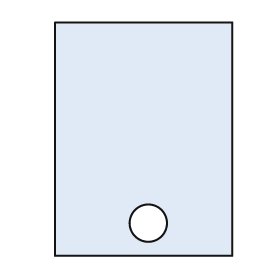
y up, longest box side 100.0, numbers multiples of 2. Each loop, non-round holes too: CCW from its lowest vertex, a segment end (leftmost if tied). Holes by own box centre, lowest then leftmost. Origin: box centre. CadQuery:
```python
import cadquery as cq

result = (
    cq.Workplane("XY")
    .moveTo(-38.0, -50.0)
    .lineTo(38.0, -50.0)
    .lineTo(38.0, 50.0)
    .lineTo(-38.0, 50.0)
    .close()
    .moveTo(2.0, -36.0)
    .circle(8.0)
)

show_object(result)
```